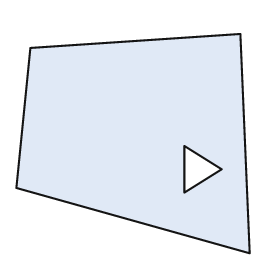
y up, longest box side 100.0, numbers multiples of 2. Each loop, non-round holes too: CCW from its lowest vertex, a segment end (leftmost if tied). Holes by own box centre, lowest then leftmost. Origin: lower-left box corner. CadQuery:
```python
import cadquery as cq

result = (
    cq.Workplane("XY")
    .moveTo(100.0, 0.0)
    .lineTo(96.0, 94.0)
    .lineTo(6.0, 88.0)
    .lineTo(0.0, 28.0)
    .close()
    .moveTo(72.0, 26.0)
    .lineTo(88.0, 36.0)
    .lineTo(72.0, 46.0)
    .close()
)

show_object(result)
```